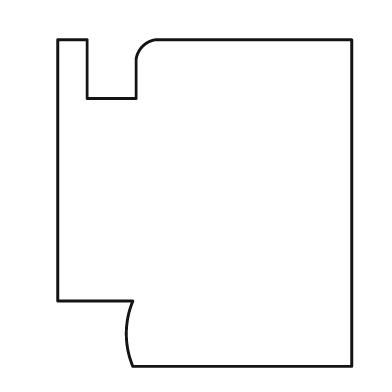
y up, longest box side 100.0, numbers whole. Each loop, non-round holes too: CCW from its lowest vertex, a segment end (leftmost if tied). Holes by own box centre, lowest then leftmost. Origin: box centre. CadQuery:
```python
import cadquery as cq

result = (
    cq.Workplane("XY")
    .moveTo(-22.0, -50.0)
    .lineTo(45.0, -50.0)
    .lineTo(45.0, 50.0)
    .lineTo(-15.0, 50.0)
    .threePointArc((-19.0, 48.0), (-21.0, 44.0))
    .lineTo(-21.0, 32.0)
    .lineTo(-36.0, 32.0)
    .lineTo(-36.0, 50.0)
    .lineTo(-45.0, 50.0)
    .lineTo(-45.0, -30.0)
    .lineTo(-22.0, -30.0)
    .threePointArc((-24.0, -40.0), (-22.0, -50.0))
    .close()
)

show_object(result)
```